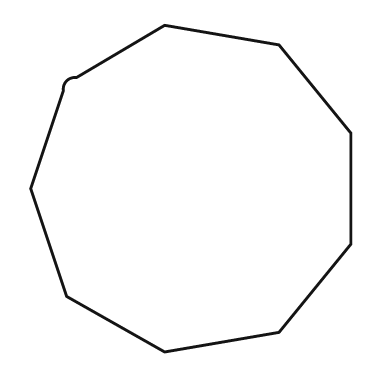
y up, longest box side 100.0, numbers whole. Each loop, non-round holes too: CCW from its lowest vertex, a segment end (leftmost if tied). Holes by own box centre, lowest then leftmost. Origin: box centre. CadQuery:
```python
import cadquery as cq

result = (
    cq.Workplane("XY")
    .moveTo(-8.0, -50.0)
    .lineTo(27.0, -44.0)
    .lineTo(49.0, -17.0)
    .lineTo(49.0, 17.0)
    .lineTo(27.0, 44.0)
    .lineTo(-8.0, 50.0)
    .lineTo(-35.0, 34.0)
    .threePointArc((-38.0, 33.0), (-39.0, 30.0))
    .lineTo(-49.0, 0.0)
    .lineTo(-38.0, -33.0)
    .close()
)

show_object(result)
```